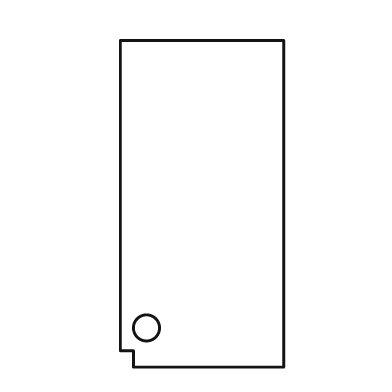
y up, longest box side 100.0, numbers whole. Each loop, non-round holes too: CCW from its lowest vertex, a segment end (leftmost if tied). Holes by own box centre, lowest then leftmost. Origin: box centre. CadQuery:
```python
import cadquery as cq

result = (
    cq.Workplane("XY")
    .moveTo(-21.0, -50.0)
    .lineTo(25.0, -50.0)
    .lineTo(25.0, 50.0)
    .lineTo(-25.0, 50.0)
    .lineTo(-25.0, -45.0)
    .lineTo(-21.0, -45.0)
    .close()
    .moveTo(-17.0, -38.0)
    .circle(4.0)
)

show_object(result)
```